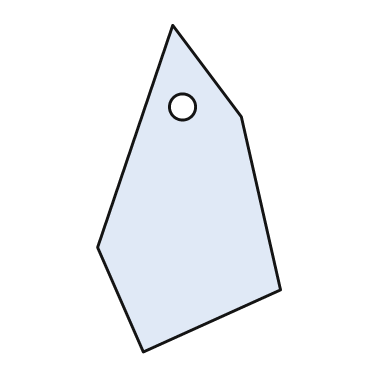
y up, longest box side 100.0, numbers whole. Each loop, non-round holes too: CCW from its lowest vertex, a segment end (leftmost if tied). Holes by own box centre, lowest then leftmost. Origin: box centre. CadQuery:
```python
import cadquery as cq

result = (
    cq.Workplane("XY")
    .moveTo(-14.0, -50.0)
    .lineTo(28.0, -31.0)
    .lineTo(16.0, 22.0)
    .lineTo(-5.0, 50.0)
    .lineTo(-28.0, -18.0)
    .close()
    .moveTo(-2.0, 25.0)
    .circle(4.0)
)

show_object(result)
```